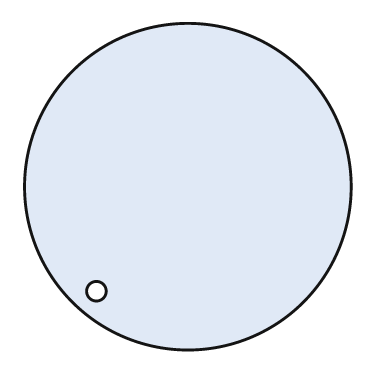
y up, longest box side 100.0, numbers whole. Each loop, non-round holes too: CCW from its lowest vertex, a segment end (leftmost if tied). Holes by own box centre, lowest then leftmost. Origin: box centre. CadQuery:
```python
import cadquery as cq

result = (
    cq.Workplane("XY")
    .moveTo(0.0, 0.0)
    .circle(50.0)
    .moveTo(-28.0, -32.0)
    .circle(3.0)
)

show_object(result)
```